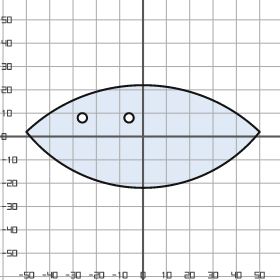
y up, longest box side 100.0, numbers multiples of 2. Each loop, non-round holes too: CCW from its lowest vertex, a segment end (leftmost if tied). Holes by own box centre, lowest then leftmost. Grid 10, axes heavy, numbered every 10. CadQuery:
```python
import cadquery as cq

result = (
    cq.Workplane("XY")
    .moveTo(-50.0, 2.0)
    .threePointArc((0.0, -22.0), (50.0, 2.0))
    .threePointArc((0.0, 22.0), (-50.0, 2.0))
    .close()
    .moveTo(-26.0, 8.0)
    .circle(2.0)
    .moveTo(-6.0, 8.0)
    .circle(2.0)
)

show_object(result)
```